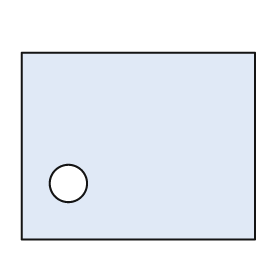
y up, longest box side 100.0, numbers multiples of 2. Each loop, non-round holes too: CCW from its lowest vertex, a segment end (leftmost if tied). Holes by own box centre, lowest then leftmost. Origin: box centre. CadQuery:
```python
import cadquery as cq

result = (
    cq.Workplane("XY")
    .moveTo(-50.0, -40.0)
    .lineTo(50.0, -40.0)
    .lineTo(50.0, 40.0)
    .lineTo(-50.0, 40.0)
    .close()
    .moveTo(-30.0, -16.0)
    .circle(8.0)
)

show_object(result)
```